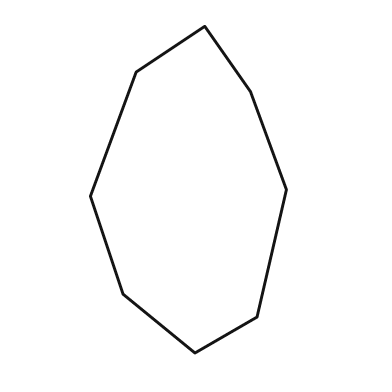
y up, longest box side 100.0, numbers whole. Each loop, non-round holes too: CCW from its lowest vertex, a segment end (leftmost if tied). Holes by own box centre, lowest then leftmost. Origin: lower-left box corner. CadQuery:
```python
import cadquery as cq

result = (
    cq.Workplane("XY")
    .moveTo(32.0, 0.0)
    .lineTo(51.0, 11.0)
    .lineTo(60.0, 50.0)
    .lineTo(49.0, 80.0)
    .lineTo(35.0, 100.0)
    .lineTo(14.0, 86.0)
    .lineTo(0.0, 48.0)
    .lineTo(10.0, 18.0)
    .close()
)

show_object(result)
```